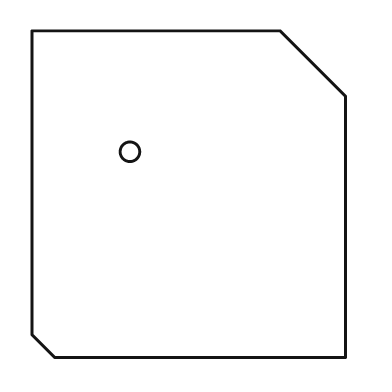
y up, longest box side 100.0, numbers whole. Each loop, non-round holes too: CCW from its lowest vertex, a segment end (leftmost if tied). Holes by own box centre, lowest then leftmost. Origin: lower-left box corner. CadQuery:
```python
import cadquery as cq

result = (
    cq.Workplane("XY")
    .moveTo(7.0, 0.0)
    .lineTo(96.0, 0.0)
    .lineTo(96.0, 80.0)
    .lineTo(76.0, 100.0)
    .lineTo(0.0, 100.0)
    .lineTo(0.0, 7.0)
    .close()
    .moveTo(30.0, 63.0)
    .circle(3.0)
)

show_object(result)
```